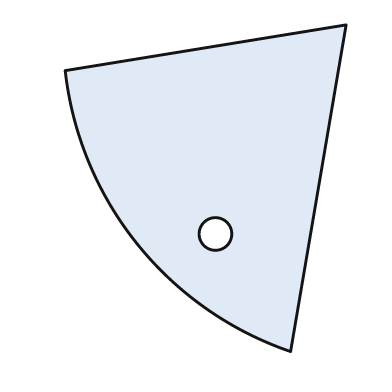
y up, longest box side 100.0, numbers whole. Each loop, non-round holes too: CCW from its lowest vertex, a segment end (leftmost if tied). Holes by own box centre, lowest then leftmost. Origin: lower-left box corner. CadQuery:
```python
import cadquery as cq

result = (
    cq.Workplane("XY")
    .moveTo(69.0, 0.0)
    .lineTo(86.0, 100.0)
    .lineTo(0.0, 86.0)
    .threePointArc((22.0, 33.0), (69.0, 0.0))
    .close()
    .moveTo(46.0, 36.0)
    .circle(5.0)
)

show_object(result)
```